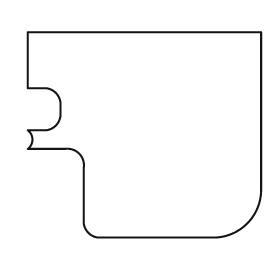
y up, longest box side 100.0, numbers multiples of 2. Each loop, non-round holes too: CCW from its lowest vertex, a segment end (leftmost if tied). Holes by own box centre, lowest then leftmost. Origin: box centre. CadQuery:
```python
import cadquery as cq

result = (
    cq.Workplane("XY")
    .moveTo(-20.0, -44.0)
    .lineTo(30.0, -44.0)
    .threePointArc((44.0, -38.0), (50.0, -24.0))
    .lineTo(50.0, 44.0)
    .lineTo(-50.0, 44.0)
    .lineTo(-50.0, 20.0)
    .lineTo(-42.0, 20.0)
    .threePointArc((-38.0, 18.0), (-36.0, 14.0))
    .lineTo(-36.0, 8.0)
    .threePointArc((-38.0, 4.0), (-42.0, 2.0))
    .lineTo(-50.0, 2.0)
    .threePointArc((-48.0, -2.0), (-50.0, -6.0))
    .lineTo(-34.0, -6.0)
    .threePointArc((-28.0, -8.0), (-26.0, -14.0))
    .lineTo(-26.0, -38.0)
    .threePointArc((-24.0, -42.0), (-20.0, -44.0))
    .close()
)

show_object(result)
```